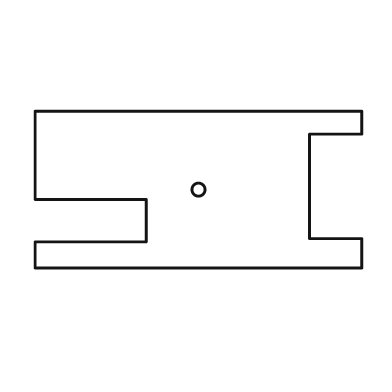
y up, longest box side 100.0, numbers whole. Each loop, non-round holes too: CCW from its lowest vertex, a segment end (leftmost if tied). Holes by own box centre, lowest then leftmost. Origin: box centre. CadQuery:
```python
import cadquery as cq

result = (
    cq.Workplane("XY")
    .moveTo(-50.0, -24.0)
    .lineTo(50.0, -24.0)
    .lineTo(50.0, -15.0)
    .lineTo(34.0, -15.0)
    .lineTo(34.0, 17.0)
    .lineTo(50.0, 17.0)
    .lineTo(50.0, 24.0)
    .lineTo(-50.0, 24.0)
    .lineTo(-50.0, -3.0)
    .lineTo(-16.0, -3.0)
    .lineTo(-16.0, -16.0)
    .lineTo(-50.0, -16.0)
    .close()
    .moveTo(0.0, 0.0)
    .circle(2.0)
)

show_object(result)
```